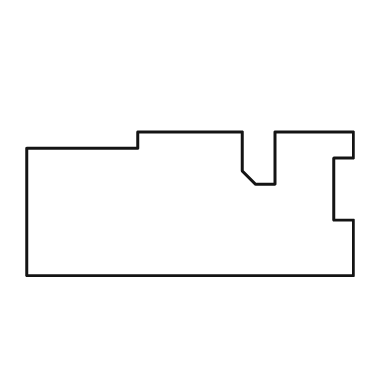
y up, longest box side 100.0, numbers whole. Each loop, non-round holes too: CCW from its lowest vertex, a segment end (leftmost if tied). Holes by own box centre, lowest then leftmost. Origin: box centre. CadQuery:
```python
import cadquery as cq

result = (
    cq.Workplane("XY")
    .moveTo(-50.0, -22.0)
    .lineTo(50.0, -22.0)
    .lineTo(50.0, -5.0)
    .lineTo(44.0, -5.0)
    .lineTo(44.0, 14.0)
    .lineTo(50.0, 14.0)
    .lineTo(50.0, 22.0)
    .lineTo(26.0, 22.0)
    .lineTo(26.0, 6.0)
    .lineTo(20.0, 6.0)
    .lineTo(16.0, 10.0)
    .lineTo(16.0, 22.0)
    .lineTo(-16.0, 22.0)
    .lineTo(-16.0, 17.0)
    .lineTo(-50.0, 17.0)
    .close()
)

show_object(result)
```